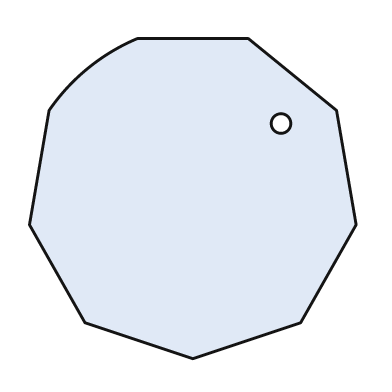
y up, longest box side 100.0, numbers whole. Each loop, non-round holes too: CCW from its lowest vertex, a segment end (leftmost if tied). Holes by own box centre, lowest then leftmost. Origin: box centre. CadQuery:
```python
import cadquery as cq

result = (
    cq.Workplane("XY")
    .moveTo(0.0, -49.0)
    .lineTo(33.0, -38.0)
    .lineTo(50.0, -8.0)
    .lineTo(44.0, 27.0)
    .lineTo(17.0, 49.0)
    .lineTo(-17.0, 49.0)
    .threePointArc((-32.0, 40.0), (-44.0, 27.0))
    .lineTo(-50.0, -8.0)
    .lineTo(-33.0, -38.0)
    .close()
    .moveTo(27.0, 23.0)
    .circle(3.0)
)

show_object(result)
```